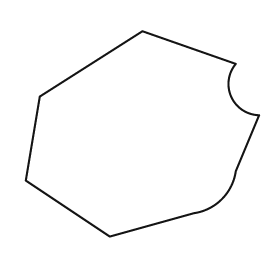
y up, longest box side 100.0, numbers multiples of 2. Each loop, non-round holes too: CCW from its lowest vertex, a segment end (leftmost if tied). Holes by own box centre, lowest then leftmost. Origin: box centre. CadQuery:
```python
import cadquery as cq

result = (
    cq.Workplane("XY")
    .moveTo(-14.0, -44.0)
    .lineTo(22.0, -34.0)
    .threePointArc((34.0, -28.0), (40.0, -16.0))
    .lineTo(50.0, 8.0)
    .threePointArc((38.0, 16.0), (40.0, 30.0))
    .lineTo(0.0, 44.0)
    .lineTo(-44.0, 16.0)
    .lineTo(-50.0, -20.0)
    .close()
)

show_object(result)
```